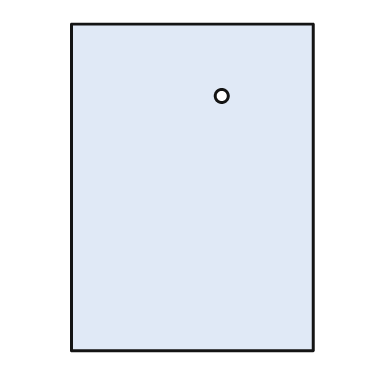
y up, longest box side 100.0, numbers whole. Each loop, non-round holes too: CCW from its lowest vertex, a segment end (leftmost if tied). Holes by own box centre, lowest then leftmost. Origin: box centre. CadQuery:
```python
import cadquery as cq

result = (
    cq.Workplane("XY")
    .moveTo(-37.0, -50.0)
    .lineTo(37.0, -50.0)
    .lineTo(37.0, 50.0)
    .lineTo(-37.0, 50.0)
    .close()
    .moveTo(9.0, 28.0)
    .circle(2.0)
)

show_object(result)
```